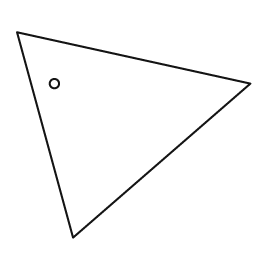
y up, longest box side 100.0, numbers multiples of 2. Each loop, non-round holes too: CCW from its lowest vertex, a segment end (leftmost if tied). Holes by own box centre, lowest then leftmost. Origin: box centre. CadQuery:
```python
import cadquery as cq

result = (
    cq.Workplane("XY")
    .moveTo(-26.0, -44.0)
    .lineTo(50.0, 22.0)
    .lineTo(-50.0, 44.0)
    .close()
    .moveTo(-34.0, 22.0)
    .circle(2.0)
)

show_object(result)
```